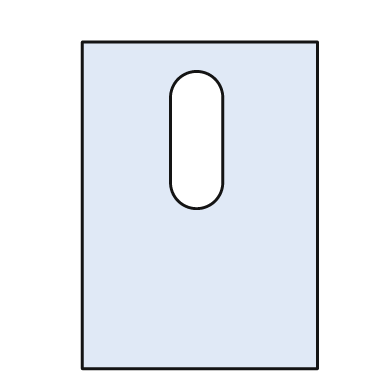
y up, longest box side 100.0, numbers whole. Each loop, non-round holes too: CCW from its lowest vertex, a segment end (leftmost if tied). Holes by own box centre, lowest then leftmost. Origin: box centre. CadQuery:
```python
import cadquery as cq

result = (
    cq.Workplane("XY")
    .moveTo(-36.0, -50.0)
    .lineTo(36.0, -50.0)
    .lineTo(36.0, 50.0)
    .lineTo(-36.0, 50.0)
    .close()
    .moveTo(-9.0, 7.0)
    .threePointArc((-1.0, -1.0), (7.0, 7.0))
    .lineTo(7.0, 33.0)
    .threePointArc((-1.0, 41.0), (-9.0, 33.0))
    .close()
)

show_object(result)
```